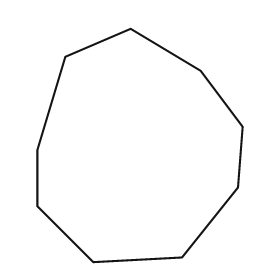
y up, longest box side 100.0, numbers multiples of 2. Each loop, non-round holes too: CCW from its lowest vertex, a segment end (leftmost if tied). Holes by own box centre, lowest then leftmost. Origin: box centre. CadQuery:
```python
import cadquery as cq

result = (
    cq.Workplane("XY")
    .moveTo(-20.0, -50.0)
    .lineTo(18.0, -48.0)
    .lineTo(42.0, -18.0)
    .lineTo(44.0, 8.0)
    .lineTo(26.0, 32.0)
    .lineTo(-4.0, 50.0)
    .lineTo(-32.0, 38.0)
    .lineTo(-44.0, -2.0)
    .lineTo(-44.0, -26.0)
    .close()
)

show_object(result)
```